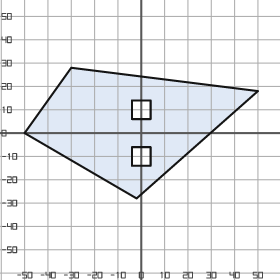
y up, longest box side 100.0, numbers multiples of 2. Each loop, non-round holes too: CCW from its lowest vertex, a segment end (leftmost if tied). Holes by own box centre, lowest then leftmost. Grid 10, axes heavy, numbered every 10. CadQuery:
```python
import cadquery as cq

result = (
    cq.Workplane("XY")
    .moveTo(-2.0, -28.0)
    .lineTo(50.0, 18.0)
    .lineTo(-30.0, 28.0)
    .lineTo(-50.0, 0.0)
    .close()
    .moveTo(-4.0, -14.0)
    .lineTo(4.0, -14.0)
    .lineTo(4.0, -6.0)
    .lineTo(-4.0, -6.0)
    .close()
    .moveTo(-4.0, 6.0)
    .lineTo(4.0, 6.0)
    .lineTo(4.0, 14.0)
    .lineTo(-4.0, 14.0)
    .close()
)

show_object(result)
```